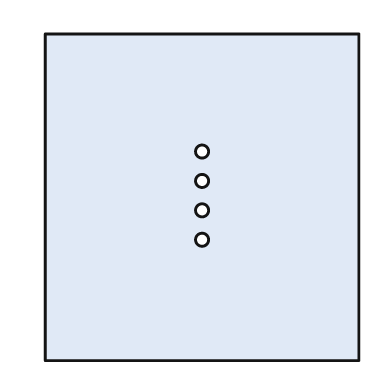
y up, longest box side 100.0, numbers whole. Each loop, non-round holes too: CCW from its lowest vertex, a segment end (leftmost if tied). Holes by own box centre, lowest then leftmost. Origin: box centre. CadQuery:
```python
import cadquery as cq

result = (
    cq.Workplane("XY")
    .moveTo(-48.0, -50.0)
    .lineTo(48.0, -50.0)
    .lineTo(48.0, 50.0)
    .lineTo(-48.0, 50.0)
    .close()
    .moveTo(0.0, -13.0)
    .circle(2.0)
    .moveTo(0.0, -4.0)
    .circle(2.0)
    .moveTo(0.0, 5.0)
    .circle(2.0)
    .moveTo(0.0, 14.0)
    .circle(2.0)
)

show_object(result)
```